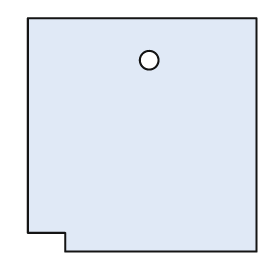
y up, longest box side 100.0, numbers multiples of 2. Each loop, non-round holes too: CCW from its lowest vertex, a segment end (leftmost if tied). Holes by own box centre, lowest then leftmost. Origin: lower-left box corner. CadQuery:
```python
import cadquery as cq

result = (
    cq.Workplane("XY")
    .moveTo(16.0, 0.0)
    .lineTo(98.0, 0.0)
    .lineTo(98.0, 100.0)
    .lineTo(0.0, 100.0)
    .lineTo(0.0, 8.0)
    .lineTo(16.0, 8.0)
    .close()
    .moveTo(52.0, 82.0)
    .circle(4.0)
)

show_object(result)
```